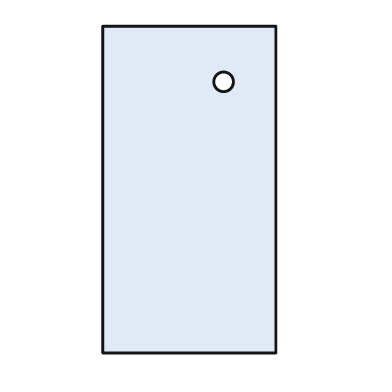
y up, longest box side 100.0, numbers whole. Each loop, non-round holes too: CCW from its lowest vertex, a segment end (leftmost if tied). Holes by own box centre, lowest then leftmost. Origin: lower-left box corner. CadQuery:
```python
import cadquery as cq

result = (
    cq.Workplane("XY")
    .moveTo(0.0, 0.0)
    .lineTo(53.0, 0.0)
    .lineTo(53.0, 100.0)
    .lineTo(0.0, 100.0)
    .close()
    .moveTo(37.0, 83.0)
    .circle(3.0)
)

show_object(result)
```